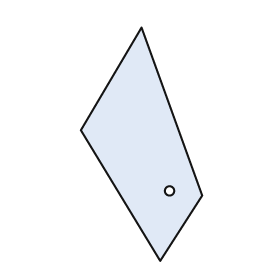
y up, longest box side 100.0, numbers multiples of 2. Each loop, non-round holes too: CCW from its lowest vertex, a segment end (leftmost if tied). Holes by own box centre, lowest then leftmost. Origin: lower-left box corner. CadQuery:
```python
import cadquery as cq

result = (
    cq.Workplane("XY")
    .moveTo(34.0, 0.0)
    .lineTo(52.0, 28.0)
    .lineTo(26.0, 100.0)
    .lineTo(0.0, 56.0)
    .close()
    .moveTo(38.0, 30.0)
    .circle(2.0)
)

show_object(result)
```